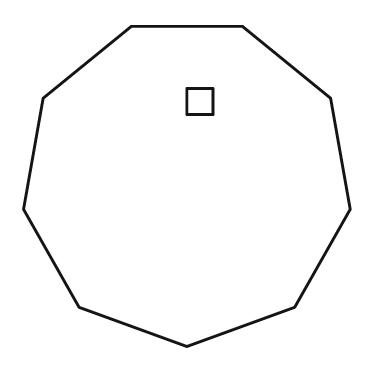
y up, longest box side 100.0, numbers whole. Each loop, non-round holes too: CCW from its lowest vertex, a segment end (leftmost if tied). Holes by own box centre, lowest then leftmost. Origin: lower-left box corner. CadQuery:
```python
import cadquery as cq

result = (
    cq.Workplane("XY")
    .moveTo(50.0, 0.0)
    .lineTo(83.0, 12.0)
    .lineTo(100.0, 42.0)
    .lineTo(94.0, 76.0)
    .lineTo(67.0, 98.0)
    .lineTo(33.0, 98.0)
    .lineTo(6.0, 76.0)
    .lineTo(0.0, 42.0)
    .lineTo(17.0, 12.0)
    .close()
    .moveTo(50.0, 71.0)
    .lineTo(58.0, 71.0)
    .lineTo(58.0, 79.0)
    .lineTo(50.0, 79.0)
    .close()
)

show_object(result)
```